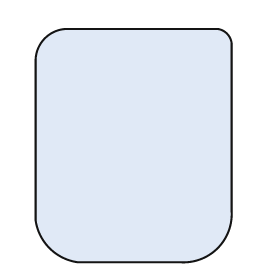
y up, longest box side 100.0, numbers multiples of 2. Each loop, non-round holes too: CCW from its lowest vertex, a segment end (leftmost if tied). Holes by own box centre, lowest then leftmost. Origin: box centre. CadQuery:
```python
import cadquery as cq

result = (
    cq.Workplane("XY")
    .moveTo(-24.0, -50.0)
    .lineTo(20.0, -50.0)
    .threePointArc((36.0, -44.0), (42.0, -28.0))
    .lineTo(42.0, 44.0)
    .threePointArc((40.0, 48.0), (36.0, 50.0))
    .lineTo(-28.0, 50.0)
    .threePointArc((-38.0, 46.0), (-42.0, 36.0))
    .lineTo(-42.0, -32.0)
    .threePointArc((-36.0, -44.0), (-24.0, -50.0))
    .close()
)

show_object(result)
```